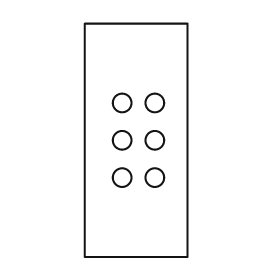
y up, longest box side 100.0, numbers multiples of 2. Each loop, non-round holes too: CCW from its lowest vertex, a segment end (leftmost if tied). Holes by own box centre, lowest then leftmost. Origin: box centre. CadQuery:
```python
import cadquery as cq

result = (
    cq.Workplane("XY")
    .moveTo(-22.0, -50.0)
    .lineTo(22.0, -50.0)
    .lineTo(22.0, 50.0)
    .lineTo(-22.0, 50.0)
    .close()
    .moveTo(-6.0, -16.0)
    .circle(4.0)
    .moveTo(8.0, -16.0)
    .circle(4.0)
    .moveTo(-6.0, 0.0)
    .circle(4.0)
    .moveTo(8.0, 0.0)
    .circle(4.0)
    .moveTo(-6.0, 16.0)
    .circle(4.0)
    .moveTo(8.0, 16.0)
    .circle(4.0)
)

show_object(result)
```